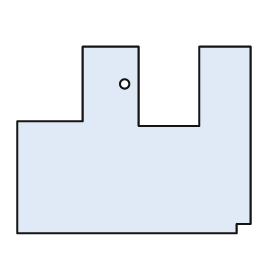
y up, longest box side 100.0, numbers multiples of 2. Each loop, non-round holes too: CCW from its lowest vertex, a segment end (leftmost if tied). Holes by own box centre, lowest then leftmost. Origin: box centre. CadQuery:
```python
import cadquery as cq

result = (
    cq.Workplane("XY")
    .moveTo(-50.0, -40.0)
    .lineTo(44.0, -40.0)
    .lineTo(44.0, -36.0)
    .lineTo(50.0, -36.0)
    .lineTo(50.0, 40.0)
    .lineTo(28.0, 40.0)
    .lineTo(28.0, 6.0)
    .lineTo(2.0, 6.0)
    .lineTo(2.0, 40.0)
    .lineTo(-22.0, 40.0)
    .lineTo(-22.0, 8.0)
    .lineTo(-50.0, 8.0)
    .close()
    .moveTo(-4.0, 24.0)
    .circle(2.0)
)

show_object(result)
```